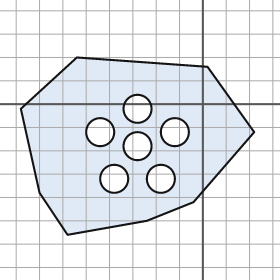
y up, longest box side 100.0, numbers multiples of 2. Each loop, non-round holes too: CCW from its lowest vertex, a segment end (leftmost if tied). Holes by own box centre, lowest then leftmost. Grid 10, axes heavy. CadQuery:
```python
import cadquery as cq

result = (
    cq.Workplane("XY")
    .moveTo(-58.0, -56.0)
    .lineTo(-24.0, -50.0)
    .lineTo(-4.0, -42.0)
    .lineTo(22.0, -12.0)
    .lineTo(2.0, 16.0)
    .lineTo(-54.0, 20.0)
    .lineTo(-78.0, -2.0)
    .lineTo(-70.0, -38.0)
    .close()
    .moveTo(-38.0, -32.0)
    .circle(6.0)
    .moveTo(-18.0, -32.0)
    .circle(6.0)
    .moveTo(-28.0, -18.0)
    .circle(6.0)
    .moveTo(-44.0, -12.0)
    .circle(6.0)
    .moveTo(-12.0, -12.0)
    .circle(6.0)
    .moveTo(-28.0, -2.0)
    .circle(6.0)
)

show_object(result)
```